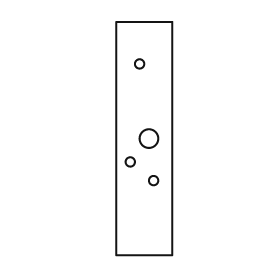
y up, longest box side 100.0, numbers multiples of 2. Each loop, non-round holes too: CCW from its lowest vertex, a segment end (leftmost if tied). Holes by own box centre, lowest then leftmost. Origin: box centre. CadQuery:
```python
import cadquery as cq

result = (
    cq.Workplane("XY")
    .moveTo(-12.0, -50.0)
    .lineTo(12.0, -50.0)
    .lineTo(12.0, 50.0)
    .lineTo(-12.0, 50.0)
    .close()
    .moveTo(4.0, -18.0)
    .circle(2.0)
    .moveTo(-6.0, -10.0)
    .circle(2.0)
    .moveTo(2.0, 0.0)
    .circle(4.0)
    .moveTo(-2.0, 32.0)
    .circle(2.0)
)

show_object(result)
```